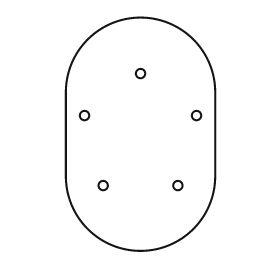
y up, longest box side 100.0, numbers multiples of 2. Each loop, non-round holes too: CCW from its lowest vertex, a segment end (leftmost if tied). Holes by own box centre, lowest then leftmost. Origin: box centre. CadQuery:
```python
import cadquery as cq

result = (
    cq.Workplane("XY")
    .moveTo(-32.0, -18.0)
    .threePointArc((0.0, -50.0), (32.0, -18.0))
    .lineTo(32.0, 18.0)
    .threePointArc((0.0, 50.0), (-32.0, 18.0))
    .close()
    .moveTo(-16.0, -22.0)
    .circle(2.0)
    .moveTo(16.0, -22.0)
    .circle(2.0)
    .moveTo(-24.0, 8.0)
    .circle(2.0)
    .moveTo(24.0, 8.0)
    .circle(2.0)
    .moveTo(0.0, 26.0)
    .circle(2.0)
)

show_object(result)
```